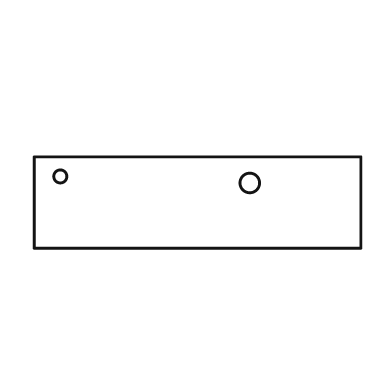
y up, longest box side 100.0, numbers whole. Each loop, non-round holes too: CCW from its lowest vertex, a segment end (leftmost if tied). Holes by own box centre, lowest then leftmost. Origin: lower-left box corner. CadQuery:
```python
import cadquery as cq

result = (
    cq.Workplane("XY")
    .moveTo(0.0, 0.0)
    .lineTo(100.0, 0.0)
    .lineTo(100.0, 28.0)
    .lineTo(0.0, 28.0)
    .close()
    .moveTo(66.0, 20.0)
    .circle(3.0)
    .moveTo(8.0, 22.0)
    .circle(2.0)
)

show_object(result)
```